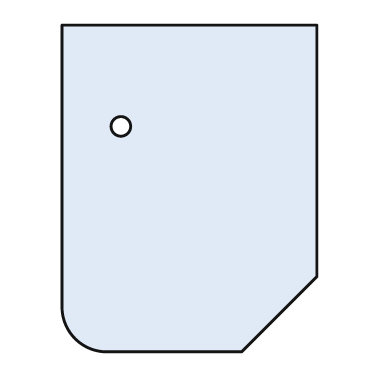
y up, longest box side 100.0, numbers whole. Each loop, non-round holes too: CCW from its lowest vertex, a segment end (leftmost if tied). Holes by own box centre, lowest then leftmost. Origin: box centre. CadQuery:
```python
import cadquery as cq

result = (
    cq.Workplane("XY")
    .moveTo(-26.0, -50.0)
    .lineTo(16.0, -50.0)
    .lineTo(39.0, -27.0)
    .lineTo(39.0, 50.0)
    .lineTo(-39.0, 50.0)
    .lineTo(-39.0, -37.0)
    .threePointArc((-35.0, -46.0), (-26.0, -50.0))
    .close()
    .moveTo(-21.0, 19.0)
    .circle(3.0)
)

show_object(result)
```